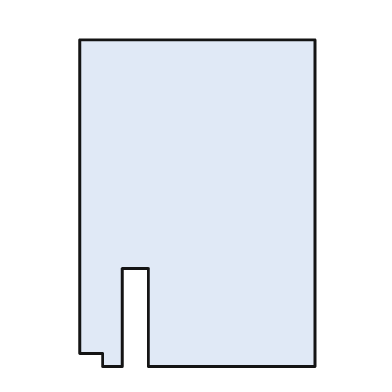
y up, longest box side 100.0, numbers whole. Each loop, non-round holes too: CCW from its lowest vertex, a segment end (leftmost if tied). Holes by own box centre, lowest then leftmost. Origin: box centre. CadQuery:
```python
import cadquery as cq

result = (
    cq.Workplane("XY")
    .moveTo(-29.0, -50.0)
    .lineTo(-23.0, -50.0)
    .lineTo(-23.0, -20.0)
    .lineTo(-15.0, -20.0)
    .lineTo(-15.0, -50.0)
    .lineTo(36.0, -50.0)
    .lineTo(36.0, 50.0)
    .lineTo(-36.0, 50.0)
    .lineTo(-36.0, -46.0)
    .lineTo(-29.0, -46.0)
    .close()
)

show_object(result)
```